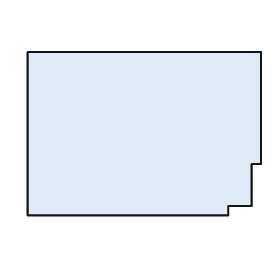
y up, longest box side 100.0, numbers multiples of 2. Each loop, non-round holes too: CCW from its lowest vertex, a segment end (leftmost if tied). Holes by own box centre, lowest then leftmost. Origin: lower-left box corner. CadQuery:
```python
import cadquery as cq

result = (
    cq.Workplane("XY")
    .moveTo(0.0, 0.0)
    .lineTo(86.0, 0.0)
    .lineTo(86.0, 4.0)
    .lineTo(96.0, 4.0)
    .lineTo(96.0, 22.0)
    .lineTo(100.0, 22.0)
    .lineTo(100.0, 70.0)
    .lineTo(0.0, 70.0)
    .close()
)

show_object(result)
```